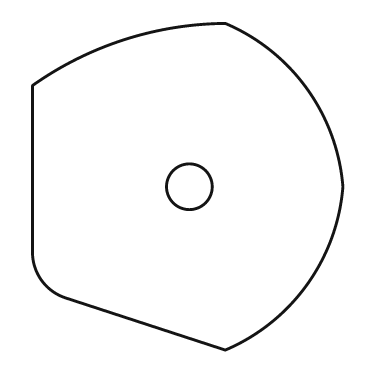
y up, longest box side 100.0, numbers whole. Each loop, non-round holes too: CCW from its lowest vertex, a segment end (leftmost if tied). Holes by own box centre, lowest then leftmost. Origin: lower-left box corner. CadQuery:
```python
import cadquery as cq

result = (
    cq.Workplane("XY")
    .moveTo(59.0, 0.0)
    .threePointArc((84.0, 20.0), (95.0, 50.0))
    .threePointArc((84.0, 80.0), (59.0, 100.0))
    .threePointArc((28.0, 95.0), (0.0, 81.0))
    .lineTo(0.0, 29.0)
    .threePointArc((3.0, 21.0), (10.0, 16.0))
    .close()
    .moveTo(48.0, 50.0)
    .circle(7.0)
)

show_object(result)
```